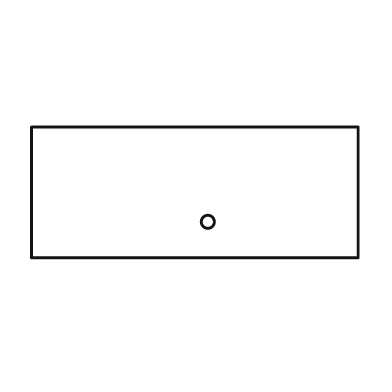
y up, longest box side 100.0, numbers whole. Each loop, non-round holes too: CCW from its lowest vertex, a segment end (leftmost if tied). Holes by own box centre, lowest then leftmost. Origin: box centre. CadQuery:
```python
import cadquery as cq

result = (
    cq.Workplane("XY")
    .moveTo(-50.0, -20.0)
    .lineTo(50.0, -20.0)
    .lineTo(50.0, 20.0)
    .lineTo(-50.0, 20.0)
    .close()
    .moveTo(4.0, -9.0)
    .circle(2.0)
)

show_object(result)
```